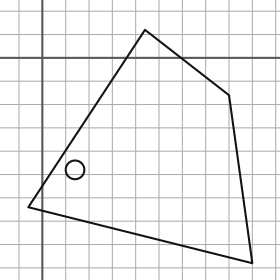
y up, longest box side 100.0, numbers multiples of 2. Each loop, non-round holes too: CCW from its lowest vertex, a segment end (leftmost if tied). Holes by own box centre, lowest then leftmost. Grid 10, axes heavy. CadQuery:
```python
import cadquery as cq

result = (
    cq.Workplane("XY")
    .moveTo(90.0, -88.0)
    .lineTo(80.0, -16.0)
    .lineTo(44.0, 12.0)
    .lineTo(-6.0, -64.0)
    .close()
    .moveTo(14.0, -48.0)
    .circle(4.0)
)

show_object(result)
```